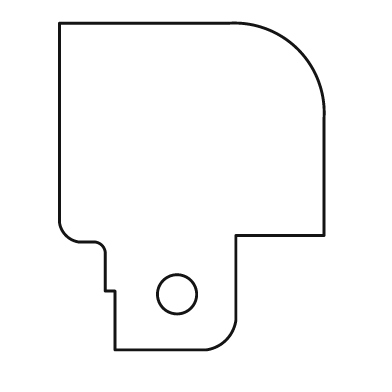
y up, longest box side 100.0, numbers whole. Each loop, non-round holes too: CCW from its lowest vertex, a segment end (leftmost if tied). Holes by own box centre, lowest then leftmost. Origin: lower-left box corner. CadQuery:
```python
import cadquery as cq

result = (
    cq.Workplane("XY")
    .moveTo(17.0, 0.0)
    .lineTo(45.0, 0.0)
    .threePointArc((51.0, 3.0), (54.0, 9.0))
    .lineTo(54.0, 35.0)
    .lineTo(81.0, 35.0)
    .lineTo(81.0, 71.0)
    .threePointArc((73.0, 92.0), (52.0, 100.0))
    .lineTo(0.0, 100.0)
    .lineTo(0.0, 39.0)
    .threePointArc((2.0, 35.0), (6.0, 33.0))
    .lineTo(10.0, 33.0)
    .threePointArc((13.0, 32.0), (14.0, 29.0))
    .lineTo(14.0, 18.0)
    .lineTo(17.0, 18.0)
    .close()
    .moveTo(36.0, 17.0)
    .circle(6.0)
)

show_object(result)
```